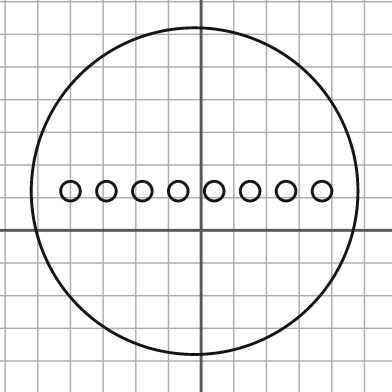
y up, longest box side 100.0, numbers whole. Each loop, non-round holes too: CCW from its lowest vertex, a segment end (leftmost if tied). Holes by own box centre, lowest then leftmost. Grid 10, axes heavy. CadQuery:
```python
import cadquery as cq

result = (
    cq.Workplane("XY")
    .moveTo(-2.0, 12.0)
    .circle(50.0)
    .moveTo(-40.0, 12.0)
    .circle(3.0)
    .moveTo(-29.0, 12.0)
    .circle(3.0)
    .moveTo(-18.0, 12.0)
    .circle(3.0)
    .moveTo(-7.0, 12.0)
    .circle(3.0)
    .moveTo(4.0, 12.0)
    .circle(3.0)
    .moveTo(15.0, 12.0)
    .circle(3.0)
    .moveTo(26.0, 12.0)
    .circle(3.0)
    .moveTo(37.0, 12.0)
    .circle(3.0)
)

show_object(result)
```